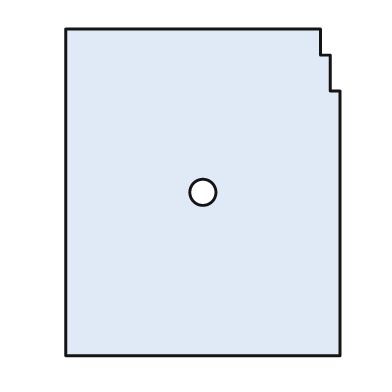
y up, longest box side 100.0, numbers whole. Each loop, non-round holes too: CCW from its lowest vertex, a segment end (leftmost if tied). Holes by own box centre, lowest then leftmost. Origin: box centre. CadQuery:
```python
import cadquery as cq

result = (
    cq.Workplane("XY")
    .moveTo(-42.0, -50.0)
    .lineTo(42.0, -50.0)
    .lineTo(42.0, 31.0)
    .lineTo(39.0, 31.0)
    .lineTo(39.0, 42.0)
    .lineTo(36.0, 42.0)
    .lineTo(36.0, 50.0)
    .lineTo(-42.0, 50.0)
    .close()
    .moveTo(0.0, 0.0)
    .circle(4.0)
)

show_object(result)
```